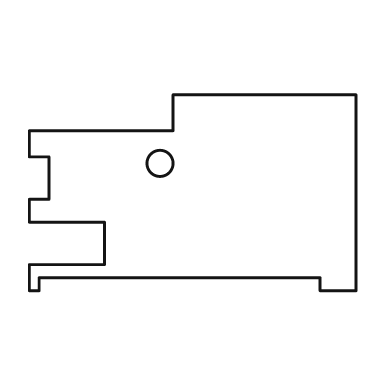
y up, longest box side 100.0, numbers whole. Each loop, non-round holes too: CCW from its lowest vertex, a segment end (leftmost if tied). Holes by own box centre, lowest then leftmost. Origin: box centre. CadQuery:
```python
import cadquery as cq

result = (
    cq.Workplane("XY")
    .moveTo(-50.0, -30.0)
    .lineTo(-47.0, -30.0)
    .lineTo(-47.0, -26.0)
    .lineTo(39.0, -26.0)
    .lineTo(39.0, -30.0)
    .lineTo(50.0, -30.0)
    .lineTo(50.0, 30.0)
    .lineTo(-6.0, 30.0)
    .lineTo(-6.0, 19.0)
    .lineTo(-50.0, 19.0)
    .lineTo(-50.0, 11.0)
    .lineTo(-44.0, 11.0)
    .lineTo(-44.0, -2.0)
    .lineTo(-50.0, -2.0)
    .lineTo(-50.0, -9.0)
    .lineTo(-27.0, -9.0)
    .lineTo(-27.0, -22.0)
    .lineTo(-50.0, -22.0)
    .close()
    .moveTo(-10.0, 9.0)
    .circle(4.0)
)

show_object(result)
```